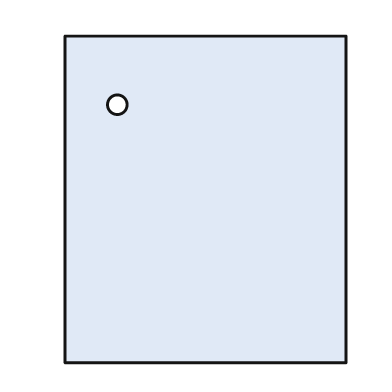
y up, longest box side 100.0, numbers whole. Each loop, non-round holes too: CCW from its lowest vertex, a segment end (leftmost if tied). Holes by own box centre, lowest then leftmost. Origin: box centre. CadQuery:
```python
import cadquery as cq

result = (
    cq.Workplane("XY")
    .moveTo(-43.0, -50.0)
    .lineTo(43.0, -50.0)
    .lineTo(43.0, 50.0)
    .lineTo(-43.0, 50.0)
    .close()
    .moveTo(-27.0, 29.0)
    .circle(3.0)
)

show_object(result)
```